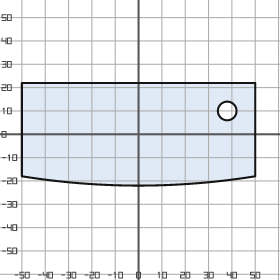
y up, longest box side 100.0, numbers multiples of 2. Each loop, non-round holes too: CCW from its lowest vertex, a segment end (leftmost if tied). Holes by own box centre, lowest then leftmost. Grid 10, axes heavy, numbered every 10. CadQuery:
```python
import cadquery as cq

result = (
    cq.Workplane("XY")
    .moveTo(-50.0, -18.0)
    .threePointArc((0.0, -22.0), (50.0, -18.0))
    .lineTo(50.0, 22.0)
    .lineTo(-50.0, 22.0)
    .close()
    .moveTo(38.0, 10.0)
    .circle(4.0)
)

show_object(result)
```